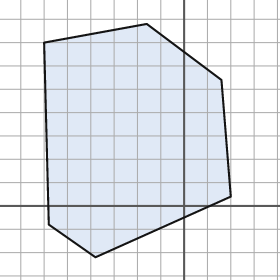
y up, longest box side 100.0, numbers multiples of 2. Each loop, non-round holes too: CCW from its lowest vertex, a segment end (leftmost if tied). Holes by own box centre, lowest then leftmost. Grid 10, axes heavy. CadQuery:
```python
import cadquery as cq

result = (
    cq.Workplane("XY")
    .moveTo(-38.0, -22.0)
    .lineTo(20.0, 4.0)
    .lineTo(16.0, 54.0)
    .lineTo(-16.0, 78.0)
    .lineTo(-60.0, 70.0)
    .lineTo(-58.0, -8.0)
    .close()
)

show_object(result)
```